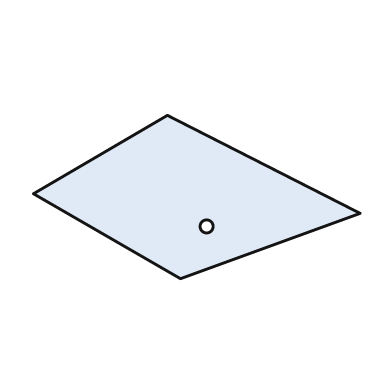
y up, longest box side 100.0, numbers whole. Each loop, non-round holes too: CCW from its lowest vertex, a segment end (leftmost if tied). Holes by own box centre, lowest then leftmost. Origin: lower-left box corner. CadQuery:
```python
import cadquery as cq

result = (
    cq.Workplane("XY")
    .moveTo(45.0, 0.0)
    .lineTo(100.0, 20.0)
    .lineTo(41.0, 50.0)
    .lineTo(0.0, 26.0)
    .close()
    .moveTo(53.0, 16.0)
    .circle(2.0)
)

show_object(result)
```